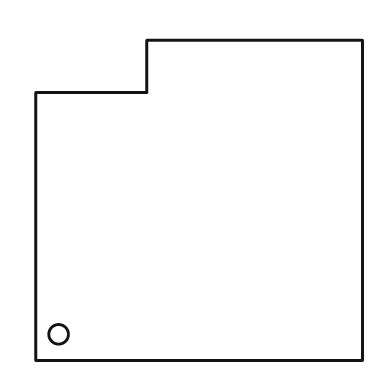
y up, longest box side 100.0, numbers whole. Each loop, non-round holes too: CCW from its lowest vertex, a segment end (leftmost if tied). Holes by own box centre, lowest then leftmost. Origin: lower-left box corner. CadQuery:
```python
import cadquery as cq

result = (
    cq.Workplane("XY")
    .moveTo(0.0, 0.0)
    .lineTo(100.0, 0.0)
    .lineTo(100.0, 98.0)
    .lineTo(34.0, 98.0)
    .lineTo(34.0, 82.0)
    .lineTo(0.0, 82.0)
    .close()
    .moveTo(7.0, 8.0)
    .circle(3.0)
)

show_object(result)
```